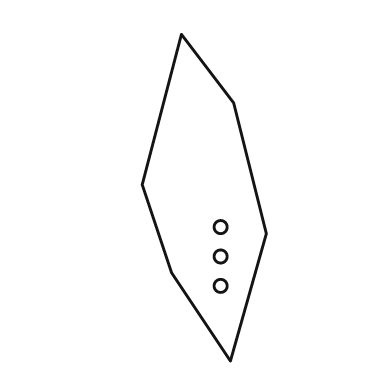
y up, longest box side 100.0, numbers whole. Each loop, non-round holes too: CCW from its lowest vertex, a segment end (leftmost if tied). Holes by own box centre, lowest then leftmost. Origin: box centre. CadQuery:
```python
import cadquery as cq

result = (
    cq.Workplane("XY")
    .moveTo(8.0, -50.0)
    .lineTo(19.0, -11.0)
    .lineTo(9.0, 29.0)
    .lineTo(-7.0, 50.0)
    .lineTo(-19.0, 4.0)
    .lineTo(-10.0, -23.0)
    .close()
    .moveTo(5.0, -27.0)
    .circle(2.0)
    .moveTo(5.0, -18.0)
    .circle(2.0)
    .moveTo(5.0, -9.0)
    .circle(2.0)
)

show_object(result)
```